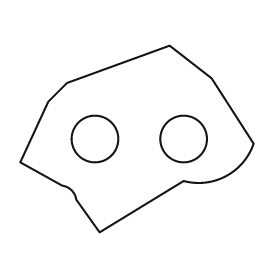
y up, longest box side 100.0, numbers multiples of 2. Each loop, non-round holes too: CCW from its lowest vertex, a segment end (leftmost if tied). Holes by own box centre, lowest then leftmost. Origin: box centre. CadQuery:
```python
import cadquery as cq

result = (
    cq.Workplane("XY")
    .moveTo(-16.0, -40.0)
    .lineTo(20.0, -18.0)
    .threePointArc((38.0, -16.0), (50.0, -2.0))
    .lineTo(32.0, 26.0)
    .lineTo(14.0, 40.0)
    .lineTo(-30.0, 24.0)
    .lineTo(-38.0, 16.0)
    .lineTo(-50.0, -10.0)
    .lineTo(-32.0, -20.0)
    .threePointArc((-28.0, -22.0), (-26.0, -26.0))
    .close()
    .moveTo(-18.0, 0.0)
    .circle(10.0)
    .moveTo(20.0, 0.0)
    .circle(10.0)
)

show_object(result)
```